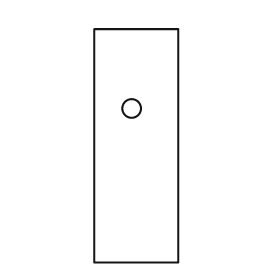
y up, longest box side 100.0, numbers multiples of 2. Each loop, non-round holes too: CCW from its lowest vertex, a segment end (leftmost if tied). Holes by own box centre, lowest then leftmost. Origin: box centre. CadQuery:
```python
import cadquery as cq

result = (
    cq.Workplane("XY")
    .moveTo(-18.0, -50.0)
    .lineTo(18.0, -50.0)
    .lineTo(18.0, 50.0)
    .lineTo(-18.0, 50.0)
    .close()
    .moveTo(-2.0, 16.0)
    .circle(4.0)
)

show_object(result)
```